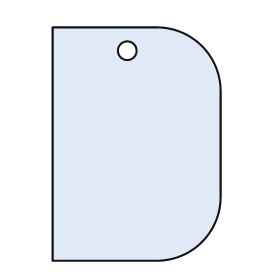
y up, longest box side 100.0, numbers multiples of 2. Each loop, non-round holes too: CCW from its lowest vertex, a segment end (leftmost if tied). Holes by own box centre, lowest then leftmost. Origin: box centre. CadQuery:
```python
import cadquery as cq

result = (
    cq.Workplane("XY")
    .moveTo(-36.0, -50.0)
    .lineTo(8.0, -50.0)
    .threePointArc((28.0, -42.0), (36.0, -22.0))
    .lineTo(36.0, 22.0)
    .threePointArc((28.0, 42.0), (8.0, 50.0))
    .lineTo(-36.0, 50.0)
    .close()
    .moveTo(-4.0, 40.0)
    .circle(4.0)
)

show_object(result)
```